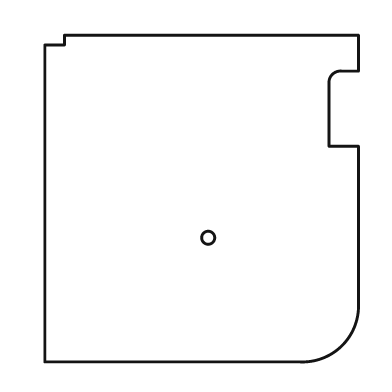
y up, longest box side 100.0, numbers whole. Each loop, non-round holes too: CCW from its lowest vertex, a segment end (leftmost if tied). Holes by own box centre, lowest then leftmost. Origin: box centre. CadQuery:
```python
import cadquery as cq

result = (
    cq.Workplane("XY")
    .moveTo(-48.0, -50.0)
    .lineTo(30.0, -50.0)
    .threePointArc((43.0, -45.0), (48.0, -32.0))
    .lineTo(48.0, 16.0)
    .lineTo(39.0, 16.0)
    .lineTo(39.0, 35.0)
    .threePointArc((40.0, 38.0), (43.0, 39.0))
    .lineTo(48.0, 39.0)
    .lineTo(48.0, 50.0)
    .lineTo(-42.0, 50.0)
    .lineTo(-42.0, 47.0)
    .lineTo(-48.0, 47.0)
    .close()
    .moveTo(2.0, -12.0)
    .circle(2.0)
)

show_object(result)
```